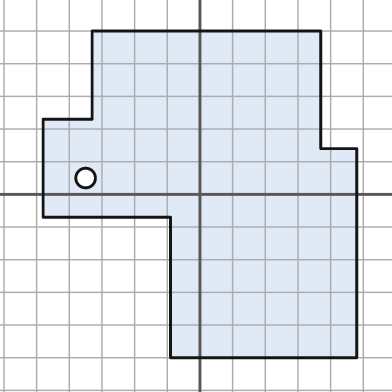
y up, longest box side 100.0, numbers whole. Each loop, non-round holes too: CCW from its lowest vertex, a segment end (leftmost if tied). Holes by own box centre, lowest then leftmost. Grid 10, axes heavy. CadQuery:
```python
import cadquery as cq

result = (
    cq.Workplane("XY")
    .moveTo(-9.0, -50.0)
    .lineTo(48.0, -50.0)
    .lineTo(48.0, 14.0)
    .lineTo(37.0, 14.0)
    .lineTo(37.0, 50.0)
    .lineTo(-33.0, 50.0)
    .lineTo(-33.0, 23.0)
    .lineTo(-48.0, 23.0)
    .lineTo(-48.0, -7.0)
    .lineTo(-9.0, -7.0)
    .close()
    .moveTo(-35.0, 5.0)
    .circle(3.0)
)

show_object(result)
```